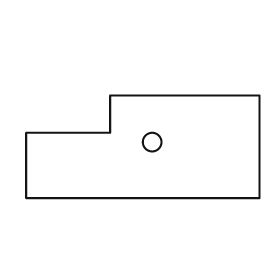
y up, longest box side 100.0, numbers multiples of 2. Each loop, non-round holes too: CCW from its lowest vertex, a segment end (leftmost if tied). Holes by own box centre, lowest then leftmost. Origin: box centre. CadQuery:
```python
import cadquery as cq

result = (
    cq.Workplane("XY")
    .moveTo(-50.0, -22.0)
    .lineTo(50.0, -22.0)
    .lineTo(50.0, 22.0)
    .lineTo(-14.0, 22.0)
    .lineTo(-14.0, 6.0)
    .lineTo(-50.0, 6.0)
    .close()
    .moveTo(4.0, 2.0)
    .circle(4.0)
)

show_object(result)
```